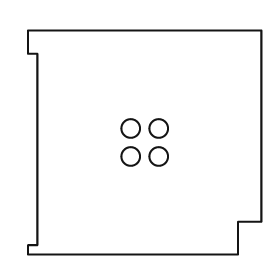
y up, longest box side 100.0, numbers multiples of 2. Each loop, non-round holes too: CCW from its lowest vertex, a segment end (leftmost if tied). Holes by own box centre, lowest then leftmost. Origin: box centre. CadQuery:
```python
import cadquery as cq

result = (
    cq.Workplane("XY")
    .moveTo(-50.0, -48.0)
    .lineTo(40.0, -48.0)
    .lineTo(40.0, -34.0)
    .lineTo(50.0, -34.0)
    .lineTo(50.0, 48.0)
    .lineTo(-50.0, 48.0)
    .lineTo(-50.0, 38.0)
    .lineTo(-46.0, 38.0)
    .lineTo(-46.0, -44.0)
    .lineTo(-50.0, -44.0)
    .close()
    .moveTo(-6.0, -6.0)
    .circle(4.0)
    .moveTo(6.0, -6.0)
    .circle(4.0)
    .moveTo(-6.0, 6.0)
    .circle(4.0)
    .moveTo(6.0, 6.0)
    .circle(4.0)
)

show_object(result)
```